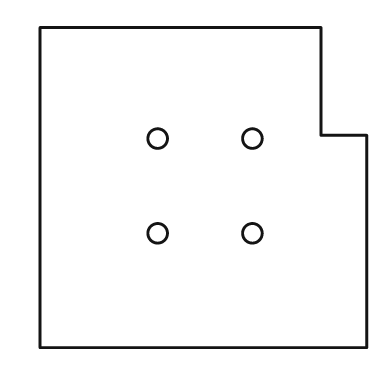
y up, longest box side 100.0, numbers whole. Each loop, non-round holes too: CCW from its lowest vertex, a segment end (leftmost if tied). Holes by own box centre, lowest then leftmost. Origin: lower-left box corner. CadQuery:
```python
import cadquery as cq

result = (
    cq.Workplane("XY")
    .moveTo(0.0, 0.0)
    .lineTo(100.0, 0.0)
    .lineTo(100.0, 65.0)
    .lineTo(86.0, 65.0)
    .lineTo(86.0, 98.0)
    .lineTo(0.0, 98.0)
    .close()
    .moveTo(36.0, 35.0)
    .circle(3.0)
    .moveTo(65.0, 35.0)
    .circle(3.0)
    .moveTo(36.0, 64.0)
    .circle(3.0)
    .moveTo(65.0, 64.0)
    .circle(3.0)
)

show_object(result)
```